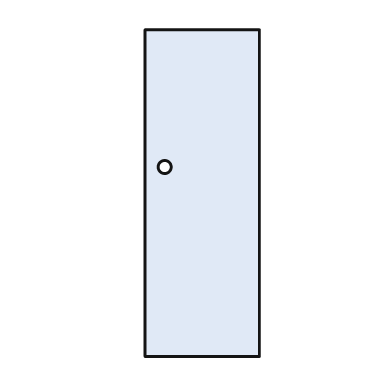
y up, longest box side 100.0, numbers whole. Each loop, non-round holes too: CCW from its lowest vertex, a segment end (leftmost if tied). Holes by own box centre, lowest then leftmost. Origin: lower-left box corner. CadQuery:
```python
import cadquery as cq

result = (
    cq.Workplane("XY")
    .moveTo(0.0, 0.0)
    .lineTo(35.0, 0.0)
    .lineTo(35.0, 100.0)
    .lineTo(0.0, 100.0)
    .close()
    .moveTo(6.0, 58.0)
    .circle(2.0)
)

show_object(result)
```